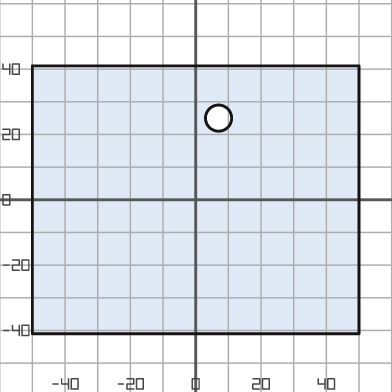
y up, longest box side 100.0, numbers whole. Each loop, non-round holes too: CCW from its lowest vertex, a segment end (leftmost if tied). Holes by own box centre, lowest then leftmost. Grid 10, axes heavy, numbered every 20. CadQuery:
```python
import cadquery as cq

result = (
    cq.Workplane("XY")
    .moveTo(-50.0, -41.0)
    .lineTo(50.0, -41.0)
    .lineTo(50.0, 41.0)
    .lineTo(-50.0, 41.0)
    .close()
    .moveTo(7.0, 25.0)
    .circle(4.0)
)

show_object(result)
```